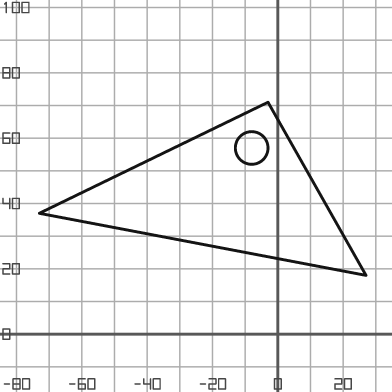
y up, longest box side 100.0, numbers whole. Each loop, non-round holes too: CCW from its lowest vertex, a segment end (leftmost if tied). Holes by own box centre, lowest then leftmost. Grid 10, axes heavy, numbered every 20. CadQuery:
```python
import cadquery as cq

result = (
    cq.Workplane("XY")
    .moveTo(27.0, 18.0)
    .lineTo(-3.0, 71.0)
    .lineTo(-73.0, 37.0)
    .close()
    .moveTo(-8.0, 57.0)
    .circle(5.0)
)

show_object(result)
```